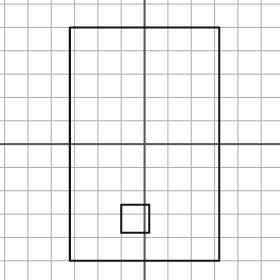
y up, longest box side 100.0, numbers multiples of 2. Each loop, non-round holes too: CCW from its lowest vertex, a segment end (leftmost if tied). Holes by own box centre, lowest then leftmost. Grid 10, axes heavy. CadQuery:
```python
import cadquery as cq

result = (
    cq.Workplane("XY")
    .moveTo(-32.0, -50.0)
    .lineTo(32.0, -50.0)
    .lineTo(32.0, 50.0)
    .lineTo(-32.0, 50.0)
    .close()
    .moveTo(-10.0, -38.0)
    .lineTo(2.0, -38.0)
    .lineTo(2.0, -26.0)
    .lineTo(-10.0, -26.0)
    .close()
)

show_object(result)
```